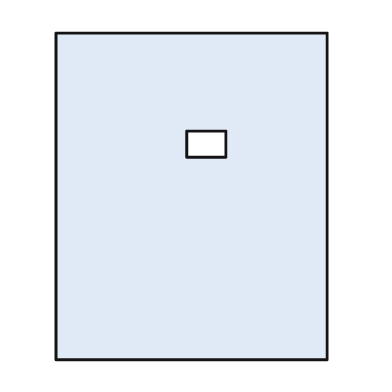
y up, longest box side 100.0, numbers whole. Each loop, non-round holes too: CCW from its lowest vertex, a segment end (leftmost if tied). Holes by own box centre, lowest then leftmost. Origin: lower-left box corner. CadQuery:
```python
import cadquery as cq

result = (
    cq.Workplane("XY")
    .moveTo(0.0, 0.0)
    .lineTo(83.0, 0.0)
    .lineTo(83.0, 100.0)
    .lineTo(0.0, 100.0)
    .close()
    .moveTo(40.0, 62.0)
    .lineTo(52.0, 62.0)
    .lineTo(52.0, 70.0)
    .lineTo(40.0, 70.0)
    .close()
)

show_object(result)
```